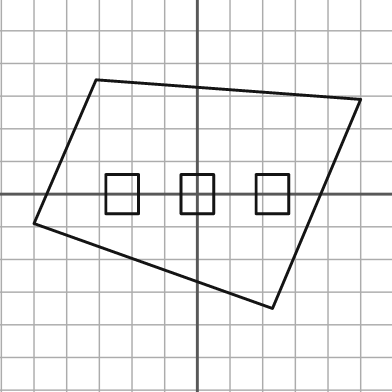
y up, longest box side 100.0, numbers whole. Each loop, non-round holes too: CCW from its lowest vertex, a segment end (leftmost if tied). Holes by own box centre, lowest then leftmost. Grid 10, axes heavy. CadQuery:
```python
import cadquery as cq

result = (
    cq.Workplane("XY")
    .moveTo(23.0, -35.0)
    .lineTo(50.0, 29.0)
    .lineTo(-31.0, 35.0)
    .lineTo(-50.0, -9.0)
    .close()
    .moveTo(-28.0, -6.0)
    .lineTo(-18.0, -6.0)
    .lineTo(-18.0, 6.0)
    .lineTo(-28.0, 6.0)
    .close()
    .moveTo(-5.0, -6.0)
    .lineTo(5.0, -6.0)
    .lineTo(5.0, 6.0)
    .lineTo(-5.0, 6.0)
    .close()
    .moveTo(18.0, -6.0)
    .lineTo(28.0, -6.0)
    .lineTo(28.0, 6.0)
    .lineTo(18.0, 6.0)
    .close()
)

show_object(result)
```